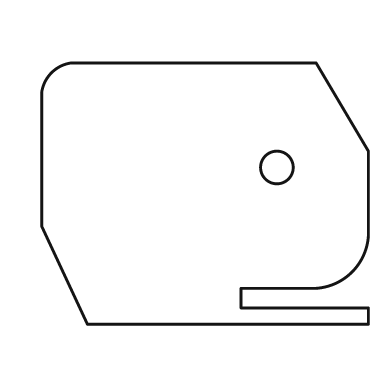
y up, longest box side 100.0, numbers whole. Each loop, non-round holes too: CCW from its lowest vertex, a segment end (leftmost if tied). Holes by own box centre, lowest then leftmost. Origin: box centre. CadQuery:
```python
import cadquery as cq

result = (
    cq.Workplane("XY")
    .moveTo(-36.0, -40.0)
    .lineTo(50.0, -40.0)
    .lineTo(50.0, -35.0)
    .lineTo(11.0, -35.0)
    .lineTo(11.0, -29.0)
    .lineTo(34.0, -29.0)
    .threePointArc((45.0, -24.0), (50.0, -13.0))
    .lineTo(50.0, 13.0)
    .lineTo(34.0, 40.0)
    .lineTo(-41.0, 40.0)
    .threePointArc((-47.0, 37.0), (-50.0, 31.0))
    .lineTo(-50.0, -10.0)
    .close()
    .moveTo(22.0, 8.0)
    .circle(5.0)
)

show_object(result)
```